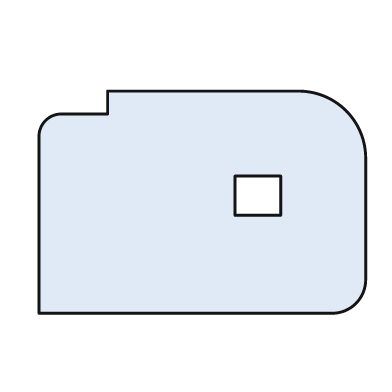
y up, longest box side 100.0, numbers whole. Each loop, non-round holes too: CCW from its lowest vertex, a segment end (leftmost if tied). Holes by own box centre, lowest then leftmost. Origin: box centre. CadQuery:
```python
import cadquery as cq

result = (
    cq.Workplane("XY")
    .moveTo(-50.0, -34.0)
    .lineTo(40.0, -34.0)
    .threePointArc((47.0, -31.0), (50.0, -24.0))
    .lineTo(50.0, 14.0)
    .threePointArc((44.0, 28.0), (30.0, 34.0))
    .lineTo(-29.0, 34.0)
    .lineTo(-29.0, 27.0)
    .lineTo(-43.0, 27.0)
    .threePointArc((-48.0, 25.0), (-50.0, 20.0))
    .close()
    .moveTo(10.0, -4.0)
    .lineTo(24.0, -4.0)
    .lineTo(24.0, 8.0)
    .lineTo(10.0, 8.0)
    .close()
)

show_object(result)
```